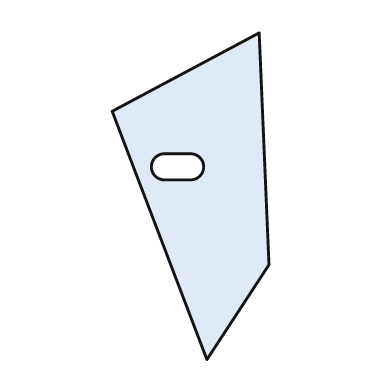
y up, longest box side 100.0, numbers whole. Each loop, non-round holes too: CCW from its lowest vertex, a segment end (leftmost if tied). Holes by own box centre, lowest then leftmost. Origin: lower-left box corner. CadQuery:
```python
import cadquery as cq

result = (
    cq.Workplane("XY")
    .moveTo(29.0, 0.0)
    .lineTo(48.0, 29.0)
    .lineTo(45.0, 100.0)
    .lineTo(0.0, 76.0)
    .close()
    .moveTo(16.0, 55.0)
    .lineTo(24.0, 55.0)
    .threePointArc((28.0, 59.0), (24.0, 63.0))
    .lineTo(16.0, 63.0)
    .threePointArc((12.0, 59.0), (16.0, 55.0))
    .close()
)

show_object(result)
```